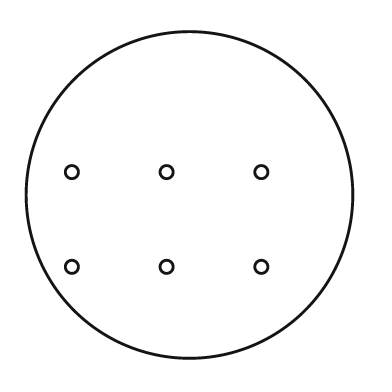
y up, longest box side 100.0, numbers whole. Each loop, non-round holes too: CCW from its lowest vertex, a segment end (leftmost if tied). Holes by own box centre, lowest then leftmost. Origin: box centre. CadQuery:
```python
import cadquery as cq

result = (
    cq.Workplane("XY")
    .moveTo(0.0, 0.0)
    .circle(50.0)
    .moveTo(-36.0, -22.0)
    .circle(2.0)
    .moveTo(-7.0, -22.0)
    .circle(2.0)
    .moveTo(22.0, -22.0)
    .circle(2.0)
    .moveTo(-36.0, 7.0)
    .circle(2.0)
    .moveTo(-7.0, 7.0)
    .circle(2.0)
    .moveTo(22.0, 7.0)
    .circle(2.0)
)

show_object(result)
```